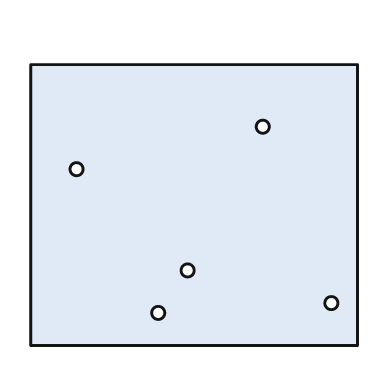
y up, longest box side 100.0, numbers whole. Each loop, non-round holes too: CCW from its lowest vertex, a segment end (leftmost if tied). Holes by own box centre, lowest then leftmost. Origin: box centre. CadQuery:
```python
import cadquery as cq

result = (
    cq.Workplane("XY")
    .moveTo(-50.0, -43.0)
    .lineTo(50.0, -43.0)
    .lineTo(50.0, 43.0)
    .lineTo(-50.0, 43.0)
    .close()
    .moveTo(-11.0, -33.0)
    .circle(2.0)
    .moveTo(42.0, -30.0)
    .circle(2.0)
    .moveTo(-2.0, -20.0)
    .circle(2.0)
    .moveTo(-36.0, 11.0)
    .circle(2.0)
    .moveTo(21.0, 24.0)
    .circle(2.0)
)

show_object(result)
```